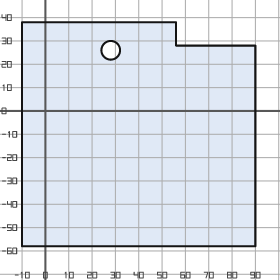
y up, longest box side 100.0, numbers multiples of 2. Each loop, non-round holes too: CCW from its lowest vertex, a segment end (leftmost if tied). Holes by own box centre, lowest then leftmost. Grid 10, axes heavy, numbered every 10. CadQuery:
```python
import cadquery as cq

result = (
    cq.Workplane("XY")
    .moveTo(-10.0, -58.0)
    .lineTo(90.0, -58.0)
    .lineTo(90.0, 28.0)
    .lineTo(56.0, 28.0)
    .lineTo(56.0, 38.0)
    .lineTo(-10.0, 38.0)
    .close()
    .moveTo(28.0, 26.0)
    .circle(4.0)
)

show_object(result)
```